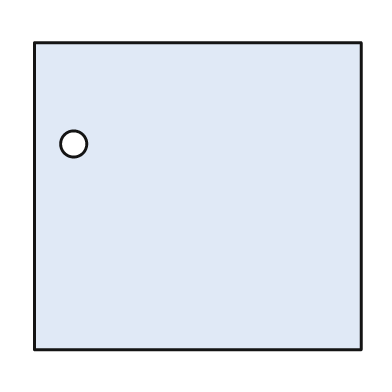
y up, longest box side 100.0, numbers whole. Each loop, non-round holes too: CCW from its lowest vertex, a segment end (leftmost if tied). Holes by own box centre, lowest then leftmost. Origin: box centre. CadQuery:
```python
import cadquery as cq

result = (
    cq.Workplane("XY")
    .moveTo(-50.0, -47.0)
    .lineTo(50.0, -47.0)
    .lineTo(50.0, 47.0)
    .lineTo(-50.0, 47.0)
    .close()
    .moveTo(-38.0, 16.0)
    .circle(4.0)
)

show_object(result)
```